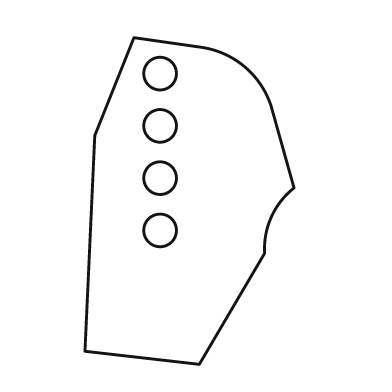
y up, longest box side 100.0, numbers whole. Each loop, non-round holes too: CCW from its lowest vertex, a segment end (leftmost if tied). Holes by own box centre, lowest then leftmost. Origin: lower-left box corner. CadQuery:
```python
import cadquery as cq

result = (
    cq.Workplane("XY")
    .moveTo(35.0, 0.0)
    .lineTo(55.0, 34.0)
    .threePointArc((57.0, 45.0), (64.0, 54.0))
    .lineTo(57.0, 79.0)
    .threePointArc((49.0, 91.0), (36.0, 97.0))
    .lineTo(15.0, 100.0)
    .lineTo(3.0, 70.0)
    .lineTo(0.0, 4.0)
    .close()
    .moveTo(23.0, 41.0)
    .circle(5.0)
    .moveTo(23.0, 57.0)
    .circle(5.0)
    .moveTo(23.0, 73.0)
    .circle(5.0)
    .moveTo(23.0, 89.0)
    .circle(5.0)
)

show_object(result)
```